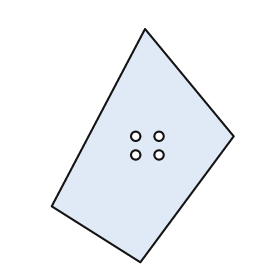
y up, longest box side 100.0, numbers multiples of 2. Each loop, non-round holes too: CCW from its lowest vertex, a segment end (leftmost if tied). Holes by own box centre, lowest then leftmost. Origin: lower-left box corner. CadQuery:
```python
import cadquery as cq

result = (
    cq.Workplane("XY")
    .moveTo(38.0, 0.0)
    .lineTo(78.0, 54.0)
    .lineTo(40.0, 100.0)
    .lineTo(0.0, 24.0)
    .close()
    .moveTo(36.0, 46.0)
    .circle(2.0)
    .moveTo(46.0, 46.0)
    .circle(2.0)
    .moveTo(36.0, 54.0)
    .circle(2.0)
    .moveTo(46.0, 54.0)
    .circle(2.0)
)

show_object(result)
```